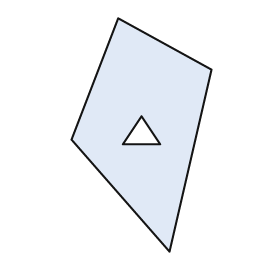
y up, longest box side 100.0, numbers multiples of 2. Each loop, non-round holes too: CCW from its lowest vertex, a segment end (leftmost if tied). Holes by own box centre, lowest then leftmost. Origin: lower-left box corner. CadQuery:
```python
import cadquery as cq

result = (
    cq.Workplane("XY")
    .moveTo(42.0, 0.0)
    .lineTo(60.0, 78.0)
    .lineTo(20.0, 100.0)
    .lineTo(0.0, 48.0)
    .close()
    .moveTo(22.0, 46.0)
    .lineTo(38.0, 46.0)
    .lineTo(30.0, 58.0)
    .close()
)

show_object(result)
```